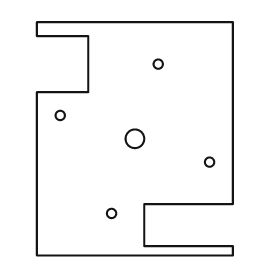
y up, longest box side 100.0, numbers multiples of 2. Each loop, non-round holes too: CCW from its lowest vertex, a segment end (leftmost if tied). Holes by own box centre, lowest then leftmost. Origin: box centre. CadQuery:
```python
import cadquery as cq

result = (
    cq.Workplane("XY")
    .moveTo(-42.0, -50.0)
    .lineTo(42.0, -50.0)
    .lineTo(42.0, -46.0)
    .lineTo(4.0, -46.0)
    .lineTo(4.0, -28.0)
    .lineTo(42.0, -28.0)
    .lineTo(42.0, 50.0)
    .lineTo(-42.0, 50.0)
    .lineTo(-42.0, 44.0)
    .lineTo(-20.0, 44.0)
    .lineTo(-20.0, 20.0)
    .lineTo(-42.0, 20.0)
    .close()
    .moveTo(-10.0, -32.0)
    .circle(2.0)
    .moveTo(32.0, -10.0)
    .circle(2.0)
    .moveTo(0.0, 0.0)
    .circle(4.0)
    .moveTo(-32.0, 10.0)
    .circle(2.0)
    .moveTo(10.0, 32.0)
    .circle(2.0)
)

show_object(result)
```